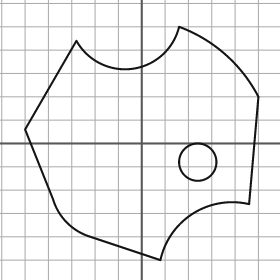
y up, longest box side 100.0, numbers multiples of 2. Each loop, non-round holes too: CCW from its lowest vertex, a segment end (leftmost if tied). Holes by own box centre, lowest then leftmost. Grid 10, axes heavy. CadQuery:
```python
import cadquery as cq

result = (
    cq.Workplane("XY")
    .moveTo(8.0, -50.0)
    .threePointArc((22.0, -30.0), (46.0, -26.0))
    .lineTo(50.0, 20.0)
    .threePointArc((36.0, 38.0), (16.0, 50.0))
    .threePointArc((-4.0, 32.0), (-28.0, 44.0))
    .lineTo(-50.0, 6.0)
    .lineTo(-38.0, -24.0)
    .threePointArc((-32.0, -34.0), (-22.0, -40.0))
    .close()
    .moveTo(24.0, -8.0)
    .circle(8.0)
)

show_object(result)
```